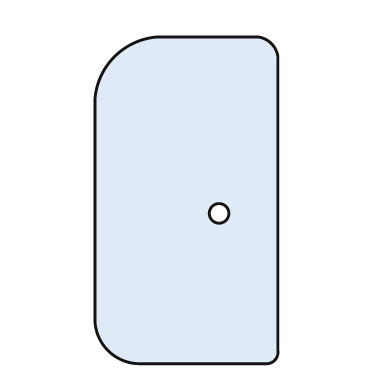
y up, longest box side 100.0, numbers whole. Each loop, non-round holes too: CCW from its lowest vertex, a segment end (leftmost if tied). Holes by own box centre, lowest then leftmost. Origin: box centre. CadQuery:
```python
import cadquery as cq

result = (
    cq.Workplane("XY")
    .moveTo(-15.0, -50.0)
    .lineTo(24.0, -50.0)
    .threePointArc((27.0, -49.0), (28.0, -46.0))
    .lineTo(28.0, 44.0)
    .threePointArc((26.0, 48.0), (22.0, 50.0))
    .lineTo(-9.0, 50.0)
    .threePointArc((-22.0, 44.0), (-28.0, 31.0))
    .lineTo(-28.0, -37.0)
    .threePointArc((-24.0, -46.0), (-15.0, -50.0))
    .close()
    .moveTo(10.0, -4.0)
    .circle(3.0)
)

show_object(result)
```